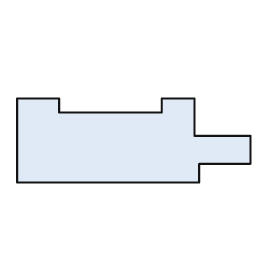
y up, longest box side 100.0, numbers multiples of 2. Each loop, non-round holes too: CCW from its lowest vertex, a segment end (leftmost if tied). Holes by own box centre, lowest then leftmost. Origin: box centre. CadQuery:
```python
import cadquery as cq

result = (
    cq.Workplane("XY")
    .moveTo(-50.0, -18.0)
    .lineTo(28.0, -18.0)
    .lineTo(28.0, -10.0)
    .lineTo(50.0, -10.0)
    .lineTo(50.0, 2.0)
    .lineTo(26.0, 2.0)
    .lineTo(26.0, 18.0)
    .lineTo(12.0, 18.0)
    .lineTo(12.0, 12.0)
    .lineTo(-32.0, 12.0)
    .lineTo(-32.0, 18.0)
    .lineTo(-50.0, 18.0)
    .close()
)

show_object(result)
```